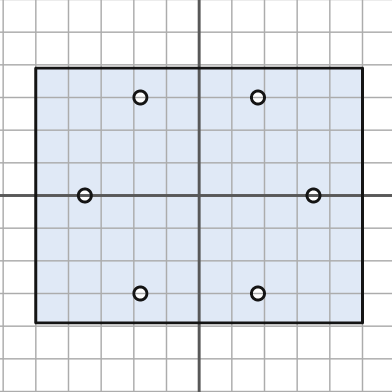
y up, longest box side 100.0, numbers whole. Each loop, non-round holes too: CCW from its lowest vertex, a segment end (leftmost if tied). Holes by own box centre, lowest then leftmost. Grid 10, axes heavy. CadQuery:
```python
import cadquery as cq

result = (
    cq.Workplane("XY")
    .moveTo(-50.0, -39.0)
    .lineTo(50.0, -39.0)
    .lineTo(50.0, 39.0)
    .lineTo(-50.0, 39.0)
    .close()
    .moveTo(-18.0, -30.0)
    .circle(2.0)
    .moveTo(18.0, -30.0)
    .circle(2.0)
    .moveTo(-35.0, 0.0)
    .circle(2.0)
    .moveTo(35.0, 0.0)
    .circle(2.0)
    .moveTo(-18.0, 30.0)
    .circle(2.0)
    .moveTo(18.0, 30.0)
    .circle(2.0)
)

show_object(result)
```